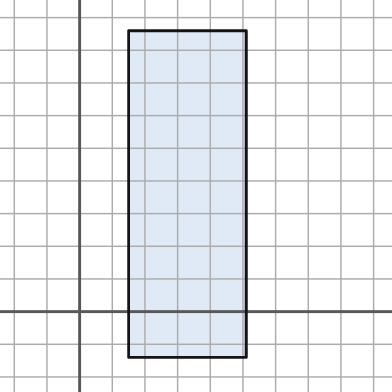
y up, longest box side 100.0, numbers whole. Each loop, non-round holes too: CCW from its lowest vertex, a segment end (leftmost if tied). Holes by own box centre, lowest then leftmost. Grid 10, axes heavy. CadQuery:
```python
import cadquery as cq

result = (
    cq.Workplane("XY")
    .moveTo(15.0, -14.0)
    .lineTo(51.0, -14.0)
    .lineTo(51.0, 86.0)
    .lineTo(15.0, 86.0)
    .close()
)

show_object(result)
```